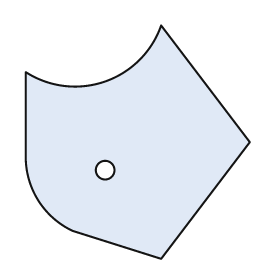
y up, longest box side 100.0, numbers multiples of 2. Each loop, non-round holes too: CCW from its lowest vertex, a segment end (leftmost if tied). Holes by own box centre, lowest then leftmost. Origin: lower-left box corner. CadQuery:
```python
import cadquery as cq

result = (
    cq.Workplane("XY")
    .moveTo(58.0, 0.0)
    .lineTo(96.0, 50.0)
    .lineTo(58.0, 100.0)
    .threePointArc((34.0, 76.0), (0.0, 80.0))
    .lineTo(0.0, 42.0)
    .threePointArc((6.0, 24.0), (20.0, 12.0))
    .close()
    .moveTo(34.0, 38.0)
    .circle(4.0)
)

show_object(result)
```